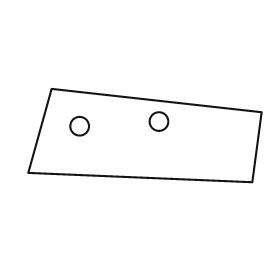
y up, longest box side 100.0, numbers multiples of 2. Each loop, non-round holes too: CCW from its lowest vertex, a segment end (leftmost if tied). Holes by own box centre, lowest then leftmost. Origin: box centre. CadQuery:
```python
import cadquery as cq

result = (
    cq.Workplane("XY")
    .moveTo(46.0, -20.0)
    .lineTo(50.0, 10.0)
    .lineTo(-40.0, 20.0)
    .lineTo(-50.0, -16.0)
    .close()
    .moveTo(-28.0, 4.0)
    .circle(4.0)
    .moveTo(6.0, 6.0)
    .circle(4.0)
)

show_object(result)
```